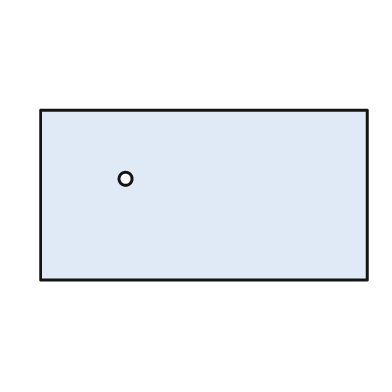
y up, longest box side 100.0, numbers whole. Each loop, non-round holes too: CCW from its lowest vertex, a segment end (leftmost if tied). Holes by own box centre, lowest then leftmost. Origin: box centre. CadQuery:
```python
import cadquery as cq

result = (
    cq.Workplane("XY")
    .moveTo(-50.0, -26.0)
    .lineTo(50.0, -26.0)
    .lineTo(50.0, 26.0)
    .lineTo(-50.0, 26.0)
    .close()
    .moveTo(-24.0, 5.0)
    .circle(2.0)
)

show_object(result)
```